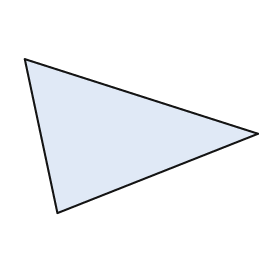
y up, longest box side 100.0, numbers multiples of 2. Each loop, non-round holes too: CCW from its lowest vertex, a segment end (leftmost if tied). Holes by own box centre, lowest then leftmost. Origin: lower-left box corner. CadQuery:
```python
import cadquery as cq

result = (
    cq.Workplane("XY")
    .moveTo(14.0, 0.0)
    .lineTo(100.0, 34.0)
    .lineTo(0.0, 66.0)
    .close()
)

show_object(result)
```